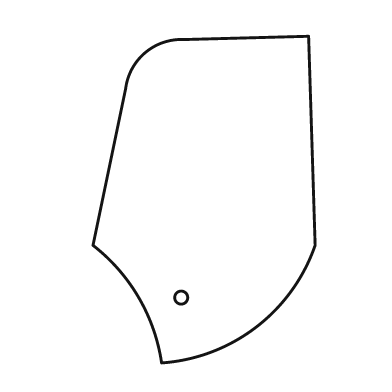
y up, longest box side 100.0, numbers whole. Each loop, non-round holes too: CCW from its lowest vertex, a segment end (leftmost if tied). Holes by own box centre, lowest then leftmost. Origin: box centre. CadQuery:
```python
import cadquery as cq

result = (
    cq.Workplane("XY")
    .moveTo(-13.0, -50.0)
    .threePointArc((16.0, -39.0), (34.0, -14.0))
    .lineTo(32.0, 50.0)
    .lineTo(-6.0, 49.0)
    .threePointArc((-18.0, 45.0), (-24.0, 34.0))
    .lineTo(-34.0, -14.0)
    .threePointArc((-20.0, -30.0), (-13.0, -50.0))
    .close()
    .moveTo(-7.0, -30.0)
    .circle(2.0)
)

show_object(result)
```